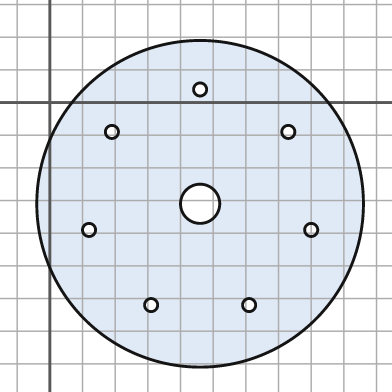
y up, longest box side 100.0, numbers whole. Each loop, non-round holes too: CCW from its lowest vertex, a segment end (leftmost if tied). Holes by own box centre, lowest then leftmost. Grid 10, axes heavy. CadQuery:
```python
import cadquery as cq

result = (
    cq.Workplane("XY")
    .moveTo(46.0, -31.0)
    .circle(50.0)
    .moveTo(31.0, -62.0)
    .circle(2.0)
    .moveTo(61.0, -62.0)
    .circle(2.0)
    .moveTo(12.0, -39.0)
    .circle(2.0)
    .moveTo(80.0, -39.0)
    .circle(2.0)
    .moveTo(46.0, -31.0)
    .circle(6.0)
    .moveTo(19.0, -9.0)
    .circle(2.0)
    .moveTo(73.0, -9.0)
    .circle(2.0)
    .moveTo(46.0, 4.0)
    .circle(2.0)
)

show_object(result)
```